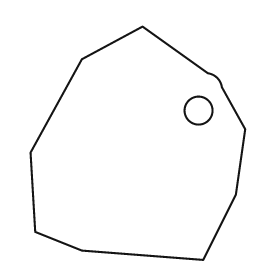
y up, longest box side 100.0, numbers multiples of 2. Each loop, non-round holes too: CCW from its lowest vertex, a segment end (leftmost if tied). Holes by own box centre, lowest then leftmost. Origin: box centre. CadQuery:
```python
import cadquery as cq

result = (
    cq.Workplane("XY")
    .moveTo(28.0, -50.0)
    .lineTo(42.0, -22.0)
    .lineTo(46.0, 6.0)
    .lineTo(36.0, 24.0)
    .threePointArc((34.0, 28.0), (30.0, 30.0))
    .lineTo(2.0, 50.0)
    .lineTo(-24.0, 36.0)
    .lineTo(-46.0, -4.0)
    .lineTo(-44.0, -38.0)
    .lineTo(-24.0, -46.0)
    .close()
    .moveTo(26.0, 14.0)
    .circle(6.0)
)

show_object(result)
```